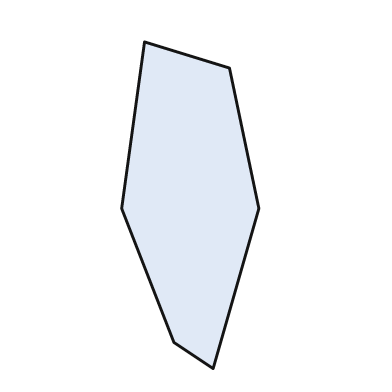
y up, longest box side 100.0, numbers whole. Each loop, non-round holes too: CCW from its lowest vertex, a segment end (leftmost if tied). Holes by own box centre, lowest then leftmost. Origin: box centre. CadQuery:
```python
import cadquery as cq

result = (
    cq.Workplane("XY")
    .moveTo(7.0, -50.0)
    .lineTo(21.0, -1.0)
    .lineTo(12.0, 42.0)
    .lineTo(-14.0, 50.0)
    .lineTo(-21.0, -1.0)
    .lineTo(-5.0, -42.0)
    .close()
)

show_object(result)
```